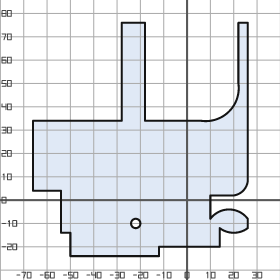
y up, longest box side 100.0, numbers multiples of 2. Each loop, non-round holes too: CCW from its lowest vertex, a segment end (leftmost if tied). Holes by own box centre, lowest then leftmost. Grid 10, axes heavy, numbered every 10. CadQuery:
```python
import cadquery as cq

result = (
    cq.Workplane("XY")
    .moveTo(-50.0, -24.0)
    .lineTo(-12.0, -24.0)
    .lineTo(-12.0, -20.0)
    .lineTo(14.0, -20.0)
    .lineTo(14.0, -12.0)
    .threePointArc((20.0, -14.0), (26.0, -12.0))
    .lineTo(26.0, -8.0)
    .threePointArc((18.0, -4.0), (10.0, -8.0))
    .lineTo(10.0, 2.0)
    .lineTo(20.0, 2.0)
    .threePointArc((24.0, 4.0), (26.0, 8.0))
    .lineTo(26.0, 76.0)
    .lineTo(22.0, 76.0)
    .lineTo(22.0, 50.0)
    .threePointArc((18.0, 38.0), (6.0, 34.0))
    .lineTo(-18.0, 34.0)
    .lineTo(-18.0, 76.0)
    .lineTo(-28.0, 76.0)
    .lineTo(-28.0, 34.0)
    .lineTo(-66.0, 34.0)
    .lineTo(-66.0, 4.0)
    .lineTo(-54.0, 4.0)
    .lineTo(-54.0, -14.0)
    .lineTo(-50.0, -14.0)
    .close()
    .moveTo(-22.0, -10.0)
    .circle(2.0)
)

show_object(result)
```